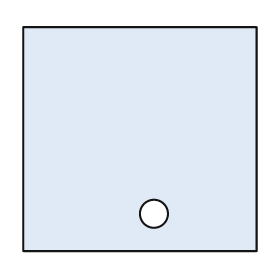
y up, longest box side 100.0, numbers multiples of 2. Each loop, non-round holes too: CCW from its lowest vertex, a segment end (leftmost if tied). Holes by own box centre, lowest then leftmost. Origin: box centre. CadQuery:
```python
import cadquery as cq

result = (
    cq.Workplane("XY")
    .moveTo(-50.0, -48.0)
    .lineTo(50.0, -48.0)
    .lineTo(50.0, 48.0)
    .lineTo(-50.0, 48.0)
    .close()
    .moveTo(6.0, -32.0)
    .circle(6.0)
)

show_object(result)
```